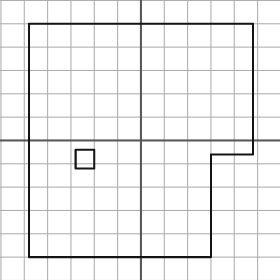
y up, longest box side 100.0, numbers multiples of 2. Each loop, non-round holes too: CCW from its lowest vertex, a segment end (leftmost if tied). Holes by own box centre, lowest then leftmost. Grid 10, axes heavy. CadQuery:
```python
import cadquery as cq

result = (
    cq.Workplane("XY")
    .moveTo(-48.0, -50.0)
    .lineTo(30.0, -50.0)
    .lineTo(30.0, -6.0)
    .lineTo(48.0, -6.0)
    .lineTo(48.0, 50.0)
    .lineTo(-48.0, 50.0)
    .close()
    .moveTo(-28.0, -12.0)
    .lineTo(-20.0, -12.0)
    .lineTo(-20.0, -4.0)
    .lineTo(-28.0, -4.0)
    .close()
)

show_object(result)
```